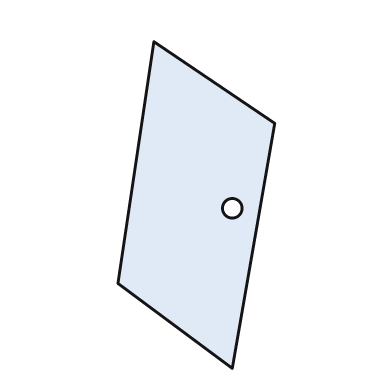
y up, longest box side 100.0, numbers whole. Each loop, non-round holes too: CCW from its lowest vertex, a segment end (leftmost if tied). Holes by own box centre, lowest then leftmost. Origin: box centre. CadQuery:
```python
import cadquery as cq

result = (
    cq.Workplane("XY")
    .moveTo(11.0, -50.0)
    .lineTo(24.0, 25.0)
    .lineTo(-13.0, 50.0)
    .lineTo(-24.0, -24.0)
    .close()
    .moveTo(11.0, -1.0)
    .circle(3.0)
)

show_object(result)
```